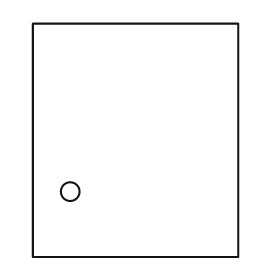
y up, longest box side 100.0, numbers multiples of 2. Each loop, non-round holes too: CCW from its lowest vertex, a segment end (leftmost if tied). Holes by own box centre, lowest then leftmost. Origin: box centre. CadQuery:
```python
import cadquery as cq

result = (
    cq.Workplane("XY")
    .moveTo(-44.0, -50.0)
    .lineTo(44.0, -50.0)
    .lineTo(44.0, 50.0)
    .lineTo(-44.0, 50.0)
    .close()
    .moveTo(-28.0, -22.0)
    .circle(4.0)
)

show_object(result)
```